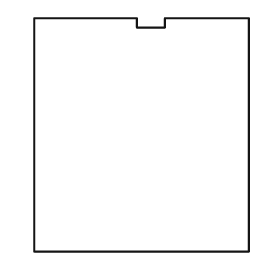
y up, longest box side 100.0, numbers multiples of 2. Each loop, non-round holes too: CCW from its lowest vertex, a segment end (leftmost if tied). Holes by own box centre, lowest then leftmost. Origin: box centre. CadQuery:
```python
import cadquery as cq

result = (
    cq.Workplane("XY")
    .moveTo(-46.0, -50.0)
    .lineTo(46.0, -50.0)
    .lineTo(46.0, 50.0)
    .lineTo(10.0, 50.0)
    .lineTo(10.0, 46.0)
    .lineTo(-2.0, 46.0)
    .lineTo(-2.0, 50.0)
    .lineTo(-46.0, 50.0)
    .close()
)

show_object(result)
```